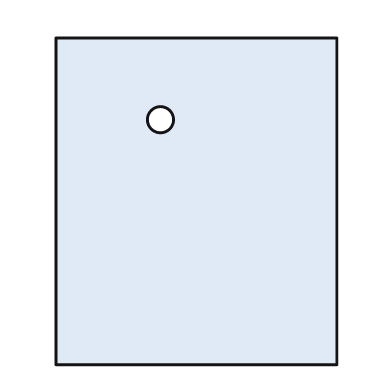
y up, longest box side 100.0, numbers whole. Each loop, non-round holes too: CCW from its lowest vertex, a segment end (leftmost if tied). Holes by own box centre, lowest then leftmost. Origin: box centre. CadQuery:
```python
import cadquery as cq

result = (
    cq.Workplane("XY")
    .moveTo(-43.0, -50.0)
    .lineTo(43.0, -50.0)
    .lineTo(43.0, 50.0)
    .lineTo(-43.0, 50.0)
    .close()
    .moveTo(-11.0, 25.0)
    .circle(4.0)
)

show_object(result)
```